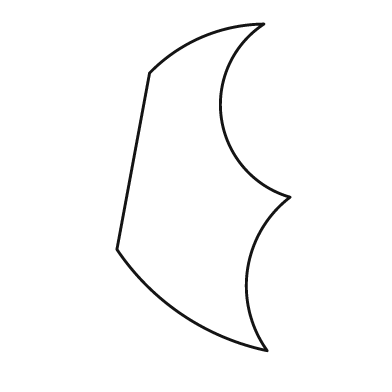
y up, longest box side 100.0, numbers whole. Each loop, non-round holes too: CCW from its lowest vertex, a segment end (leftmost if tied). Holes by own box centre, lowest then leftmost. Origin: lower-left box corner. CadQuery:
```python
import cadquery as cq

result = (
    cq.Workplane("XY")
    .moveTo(46.0, 0.0)
    .threePointArc((40.0, 25.0), (53.0, 47.0))
    .threePointArc((32.0, 71.0), (45.0, 100.0))
    .threePointArc((26.0, 96.0), (10.0, 85.0))
    .lineTo(0.0, 31.0)
    .threePointArc((20.0, 11.0), (46.0, 0.0))
    .close()
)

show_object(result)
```